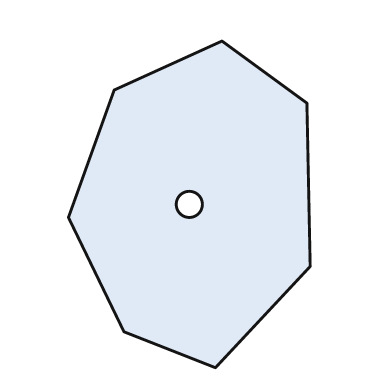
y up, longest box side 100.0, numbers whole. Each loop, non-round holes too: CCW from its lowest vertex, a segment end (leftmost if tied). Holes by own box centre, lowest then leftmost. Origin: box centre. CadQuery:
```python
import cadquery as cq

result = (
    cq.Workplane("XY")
    .moveTo(8.0, -50.0)
    .lineTo(37.0, -19.0)
    .lineTo(36.0, 31.0)
    .lineTo(10.0, 50.0)
    .lineTo(-23.0, 35.0)
    .lineTo(-37.0, -4.0)
    .lineTo(-20.0, -39.0)
    .close()
    .moveTo(0.0, 0.0)
    .circle(4.0)
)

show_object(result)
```